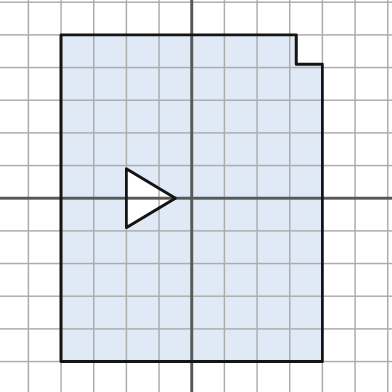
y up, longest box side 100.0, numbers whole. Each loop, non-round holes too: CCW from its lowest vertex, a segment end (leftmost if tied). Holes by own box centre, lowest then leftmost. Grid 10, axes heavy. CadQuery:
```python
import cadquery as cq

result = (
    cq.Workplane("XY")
    .moveTo(-40.0, -50.0)
    .lineTo(40.0, -50.0)
    .lineTo(40.0, 41.0)
    .lineTo(32.0, 41.0)
    .lineTo(32.0, 50.0)
    .lineTo(-40.0, 50.0)
    .close()
    .moveTo(-20.0, -9.0)
    .lineTo(-5.0, 0.0)
    .lineTo(-20.0, 9.0)
    .close()
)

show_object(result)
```